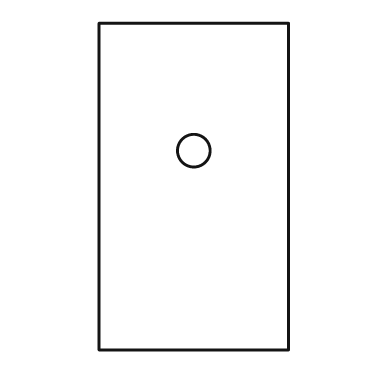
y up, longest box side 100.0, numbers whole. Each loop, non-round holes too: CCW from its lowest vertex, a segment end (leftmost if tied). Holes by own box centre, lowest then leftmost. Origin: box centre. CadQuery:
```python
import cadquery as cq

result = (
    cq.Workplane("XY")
    .moveTo(-29.0, -50.0)
    .lineTo(29.0, -50.0)
    .lineTo(29.0, 50.0)
    .lineTo(-29.0, 50.0)
    .close()
    .moveTo(0.0, 11.0)
    .circle(5.0)
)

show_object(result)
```